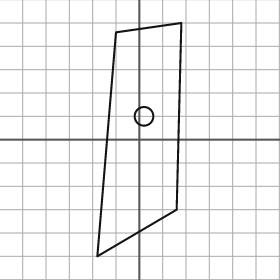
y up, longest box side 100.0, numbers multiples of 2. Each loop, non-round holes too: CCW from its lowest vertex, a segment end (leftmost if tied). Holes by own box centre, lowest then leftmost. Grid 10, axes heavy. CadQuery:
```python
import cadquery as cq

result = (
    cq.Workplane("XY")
    .moveTo(-18.0, -50.0)
    .lineTo(16.0, -30.0)
    .lineTo(18.0, 50.0)
    .lineTo(-10.0, 46.0)
    .close()
    .moveTo(2.0, 10.0)
    .circle(4.0)
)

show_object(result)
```